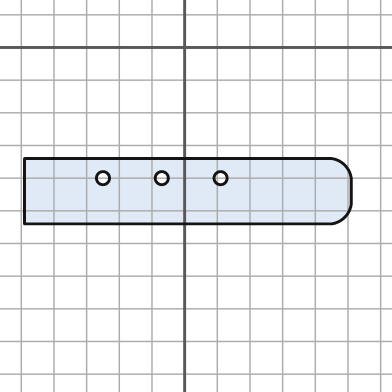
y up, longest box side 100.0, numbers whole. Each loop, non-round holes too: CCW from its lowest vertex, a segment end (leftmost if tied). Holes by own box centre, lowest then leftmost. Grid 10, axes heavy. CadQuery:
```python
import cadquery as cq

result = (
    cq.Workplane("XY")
    .moveTo(-49.0, -54.0)
    .lineTo(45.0, -54.0)
    .threePointArc((49.0, -52.0), (51.0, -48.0))
    .lineTo(51.0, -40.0)
    .threePointArc((49.0, -36.0), (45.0, -34.0))
    .lineTo(-49.0, -34.0)
    .close()
    .moveTo(-25.0, -40.0)
    .circle(2.0)
    .moveTo(-7.0, -40.0)
    .circle(2.0)
    .moveTo(11.0, -40.0)
    .circle(2.0)
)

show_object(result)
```